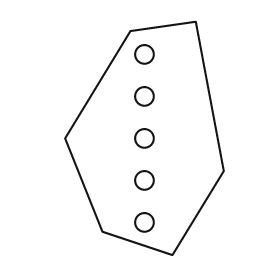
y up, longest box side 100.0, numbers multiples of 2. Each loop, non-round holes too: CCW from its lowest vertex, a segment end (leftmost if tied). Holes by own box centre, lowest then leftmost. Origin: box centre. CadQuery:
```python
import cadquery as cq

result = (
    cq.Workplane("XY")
    .moveTo(12.0, -50.0)
    .lineTo(34.0, -14.0)
    .lineTo(22.0, 50.0)
    .lineTo(-6.0, 46.0)
    .lineTo(-34.0, 0.0)
    .lineTo(-18.0, -40.0)
    .close()
    .moveTo(0.0, -36.0)
    .circle(4.0)
    .moveTo(0.0, -18.0)
    .circle(4.0)
    .moveTo(0.0, 0.0)
    .circle(4.0)
    .moveTo(0.0, 18.0)
    .circle(4.0)
    .moveTo(0.0, 36.0)
    .circle(4.0)
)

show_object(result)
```